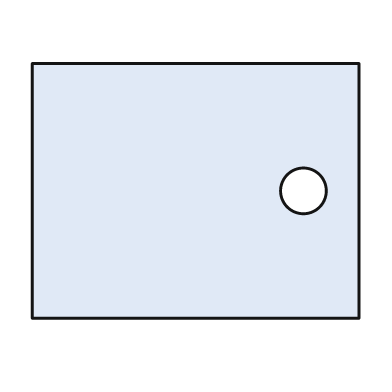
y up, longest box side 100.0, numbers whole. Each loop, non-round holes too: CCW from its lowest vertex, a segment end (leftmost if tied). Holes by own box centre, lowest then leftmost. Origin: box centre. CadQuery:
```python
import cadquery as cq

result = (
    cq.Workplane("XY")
    .moveTo(-50.0, -39.0)
    .lineTo(50.0, -39.0)
    .lineTo(50.0, 39.0)
    .lineTo(-50.0, 39.0)
    .close()
    .moveTo(33.0, 0.0)
    .circle(7.0)
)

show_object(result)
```